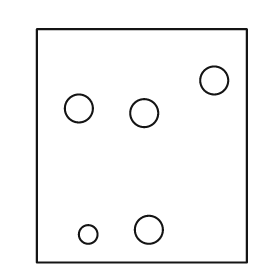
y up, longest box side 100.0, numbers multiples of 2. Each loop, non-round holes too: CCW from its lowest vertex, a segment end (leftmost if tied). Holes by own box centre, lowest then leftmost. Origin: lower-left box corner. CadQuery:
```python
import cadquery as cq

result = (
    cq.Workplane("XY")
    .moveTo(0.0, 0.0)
    .lineTo(90.0, 0.0)
    .lineTo(90.0, 100.0)
    .lineTo(0.0, 100.0)
    .close()
    .moveTo(22.0, 12.0)
    .circle(4.0)
    .moveTo(48.0, 14.0)
    .circle(6.0)
    .moveTo(46.0, 64.0)
    .circle(6.0)
    .moveTo(18.0, 66.0)
    .circle(6.0)
    .moveTo(76.0, 78.0)
    .circle(6.0)
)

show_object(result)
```